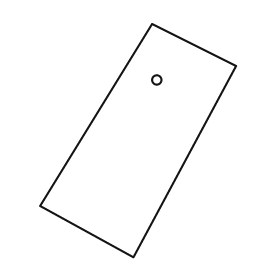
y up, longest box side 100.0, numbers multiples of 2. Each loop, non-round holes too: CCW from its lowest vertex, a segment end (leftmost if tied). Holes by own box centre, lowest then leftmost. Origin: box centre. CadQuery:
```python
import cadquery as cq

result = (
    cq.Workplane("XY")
    .moveTo(-2.0, -50.0)
    .lineTo(42.0, 32.0)
    .lineTo(6.0, 50.0)
    .lineTo(-42.0, -28.0)
    .close()
    .moveTo(8.0, 26.0)
    .circle(2.0)
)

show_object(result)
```